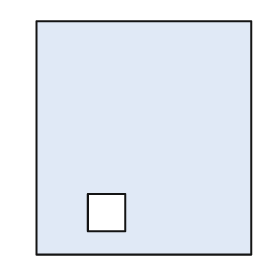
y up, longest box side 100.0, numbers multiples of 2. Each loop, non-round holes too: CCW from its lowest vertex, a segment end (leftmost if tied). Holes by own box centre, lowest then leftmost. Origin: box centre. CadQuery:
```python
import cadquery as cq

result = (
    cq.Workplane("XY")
    .moveTo(-46.0, -50.0)
    .lineTo(46.0, -50.0)
    .lineTo(46.0, 50.0)
    .lineTo(-46.0, 50.0)
    .close()
    .moveTo(-24.0, -40.0)
    .lineTo(-8.0, -40.0)
    .lineTo(-8.0, -24.0)
    .lineTo(-24.0, -24.0)
    .close()
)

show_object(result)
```